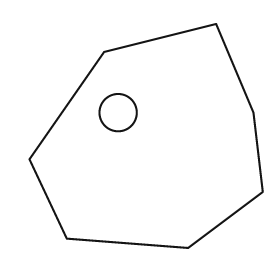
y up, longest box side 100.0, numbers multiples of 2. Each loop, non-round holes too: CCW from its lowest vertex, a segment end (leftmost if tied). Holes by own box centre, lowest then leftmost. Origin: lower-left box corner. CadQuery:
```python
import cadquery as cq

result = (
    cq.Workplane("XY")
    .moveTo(68.0, 0.0)
    .lineTo(100.0, 24.0)
    .lineTo(96.0, 58.0)
    .lineTo(80.0, 96.0)
    .lineTo(32.0, 84.0)
    .lineTo(0.0, 38.0)
    .lineTo(16.0, 4.0)
    .close()
    .moveTo(38.0, 58.0)
    .circle(8.0)
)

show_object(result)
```